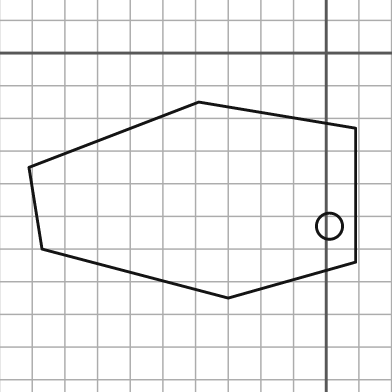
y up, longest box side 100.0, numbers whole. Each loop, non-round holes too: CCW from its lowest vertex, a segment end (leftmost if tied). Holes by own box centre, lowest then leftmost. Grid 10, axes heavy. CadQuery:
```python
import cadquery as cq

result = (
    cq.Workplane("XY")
    .moveTo(-30.0, -75.0)
    .lineTo(9.0, -64.0)
    .lineTo(9.0, -23.0)
    .lineTo(-39.0, -15.0)
    .lineTo(-91.0, -35.0)
    .lineTo(-87.0, -60.0)
    .close()
    .moveTo(1.0, -53.0)
    .circle(4.0)
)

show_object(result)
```